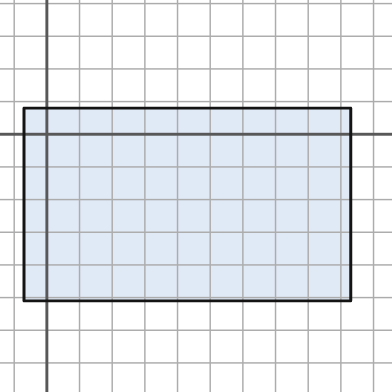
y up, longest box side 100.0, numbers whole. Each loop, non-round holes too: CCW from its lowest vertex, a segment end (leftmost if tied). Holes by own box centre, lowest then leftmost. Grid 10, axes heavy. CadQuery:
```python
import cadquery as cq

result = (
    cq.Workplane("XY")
    .moveTo(-7.0, -51.0)
    .lineTo(93.0, -51.0)
    .lineTo(93.0, 8.0)
    .lineTo(-7.0, 8.0)
    .close()
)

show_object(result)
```